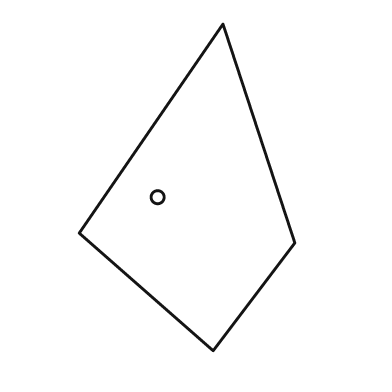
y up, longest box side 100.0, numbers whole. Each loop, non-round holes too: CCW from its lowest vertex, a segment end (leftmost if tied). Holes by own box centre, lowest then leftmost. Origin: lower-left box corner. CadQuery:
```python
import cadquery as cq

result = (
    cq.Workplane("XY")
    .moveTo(41.0, 0.0)
    .lineTo(66.0, 33.0)
    .lineTo(44.0, 100.0)
    .lineTo(0.0, 36.0)
    .close()
    .moveTo(24.0, 47.0)
    .circle(2.0)
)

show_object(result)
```